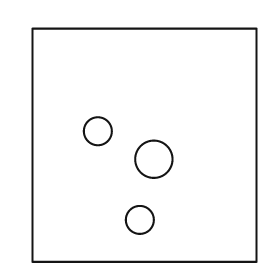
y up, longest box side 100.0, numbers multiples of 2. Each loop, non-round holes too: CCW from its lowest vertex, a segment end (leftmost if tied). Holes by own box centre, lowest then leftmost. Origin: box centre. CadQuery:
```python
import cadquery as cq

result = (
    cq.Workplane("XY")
    .moveTo(-48.0, -50.0)
    .lineTo(48.0, -50.0)
    .lineTo(48.0, 50.0)
    .lineTo(-48.0, 50.0)
    .close()
    .moveTo(-2.0, -32.0)
    .circle(6.0)
    .moveTo(4.0, -6.0)
    .circle(8.0)
    .moveTo(-20.0, 6.0)
    .circle(6.0)
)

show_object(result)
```